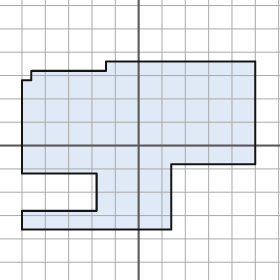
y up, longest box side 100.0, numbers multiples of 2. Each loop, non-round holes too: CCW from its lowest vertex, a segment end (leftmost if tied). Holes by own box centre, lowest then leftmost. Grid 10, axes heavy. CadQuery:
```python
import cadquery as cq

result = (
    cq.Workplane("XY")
    .moveTo(-50.0, -36.0)
    .lineTo(14.0, -36.0)
    .lineTo(14.0, -8.0)
    .lineTo(50.0, -8.0)
    .lineTo(50.0, 36.0)
    .lineTo(-14.0, 36.0)
    .lineTo(-14.0, 32.0)
    .lineTo(-46.0, 32.0)
    .lineTo(-46.0, 28.0)
    .lineTo(-50.0, 28.0)
    .lineTo(-50.0, -12.0)
    .lineTo(-18.0, -12.0)
    .lineTo(-18.0, -28.0)
    .lineTo(-50.0, -28.0)
    .close()
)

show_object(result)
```